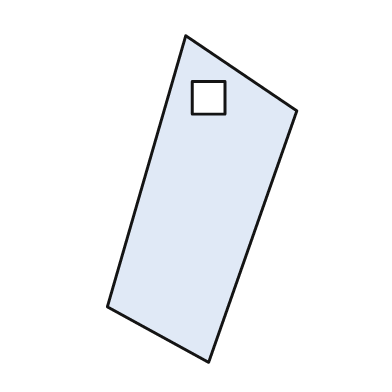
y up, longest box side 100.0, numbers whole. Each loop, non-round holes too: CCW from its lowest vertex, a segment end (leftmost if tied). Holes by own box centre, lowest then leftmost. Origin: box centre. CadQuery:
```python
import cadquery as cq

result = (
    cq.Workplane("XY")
    .moveTo(2.0, -50.0)
    .lineTo(29.0, 27.0)
    .lineTo(-5.0, 50.0)
    .lineTo(-29.0, -33.0)
    .close()
    .moveTo(-3.0, 26.0)
    .lineTo(7.0, 26.0)
    .lineTo(7.0, 36.0)
    .lineTo(-3.0, 36.0)
    .close()
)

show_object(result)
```